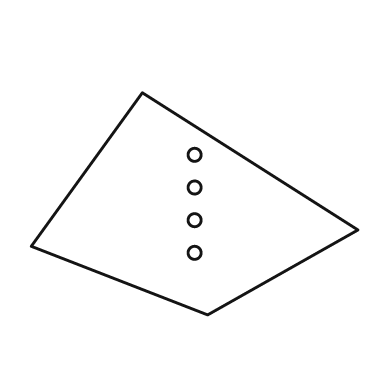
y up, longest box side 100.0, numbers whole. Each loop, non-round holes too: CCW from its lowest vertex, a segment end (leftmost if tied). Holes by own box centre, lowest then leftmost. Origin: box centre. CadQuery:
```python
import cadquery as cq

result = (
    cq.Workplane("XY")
    .moveTo(4.0, -34.0)
    .lineTo(50.0, -8.0)
    .lineTo(-16.0, 34.0)
    .lineTo(-50.0, -13.0)
    .close()
    .moveTo(0.0, -15.0)
    .circle(2.0)
    .moveTo(0.0, -5.0)
    .circle(2.0)
    .moveTo(0.0, 5.0)
    .circle(2.0)
    .moveTo(0.0, 15.0)
    .circle(2.0)
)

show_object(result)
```